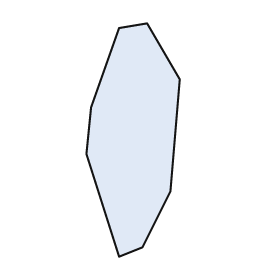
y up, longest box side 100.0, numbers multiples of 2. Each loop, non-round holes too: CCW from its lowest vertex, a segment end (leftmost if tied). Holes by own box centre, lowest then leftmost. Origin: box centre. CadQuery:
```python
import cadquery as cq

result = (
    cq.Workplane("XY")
    .moveTo(-6.0, -50.0)
    .lineTo(4.0, -46.0)
    .lineTo(16.0, -22.0)
    .lineTo(20.0, 26.0)
    .lineTo(6.0, 50.0)
    .lineTo(-6.0, 48.0)
    .lineTo(-18.0, 14.0)
    .lineTo(-20.0, -6.0)
    .close()
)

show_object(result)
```